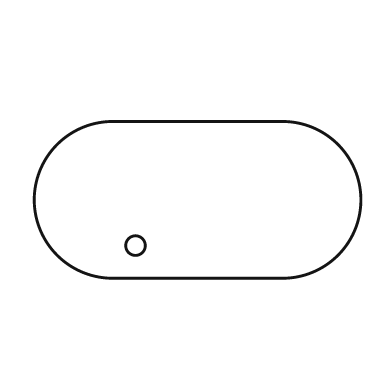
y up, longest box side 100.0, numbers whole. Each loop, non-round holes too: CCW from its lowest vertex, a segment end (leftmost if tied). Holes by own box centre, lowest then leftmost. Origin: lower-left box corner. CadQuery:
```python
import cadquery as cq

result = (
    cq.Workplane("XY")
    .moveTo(24.0, 0.0)
    .lineTo(76.0, 0.0)
    .threePointArc((100.0, 24.0), (76.0, 48.0))
    .lineTo(24.0, 48.0)
    .threePointArc((0.0, 24.0), (24.0, 0.0))
    .close()
    .moveTo(31.0, 10.0)
    .circle(3.0)
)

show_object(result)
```